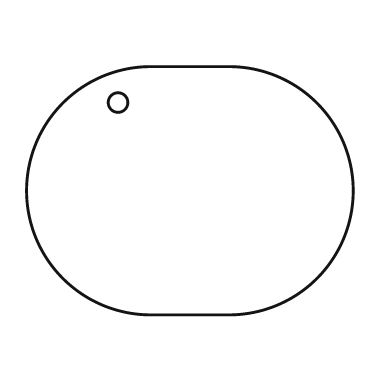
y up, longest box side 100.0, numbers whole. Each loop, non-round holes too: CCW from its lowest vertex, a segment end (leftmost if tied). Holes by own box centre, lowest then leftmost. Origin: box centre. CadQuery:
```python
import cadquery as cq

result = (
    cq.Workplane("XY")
    .moveTo(-12.0, -38.0)
    .lineTo(12.0, -38.0)
    .threePointArc((50.0, 0.0), (12.0, 38.0))
    .lineTo(-12.0, 38.0)
    .threePointArc((-50.0, 0.0), (-12.0, -38.0))
    .close()
    .moveTo(-22.0, 27.0)
    .circle(3.0)
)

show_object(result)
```